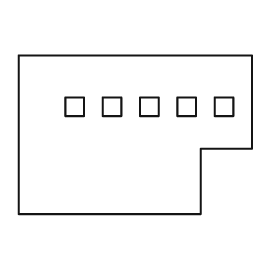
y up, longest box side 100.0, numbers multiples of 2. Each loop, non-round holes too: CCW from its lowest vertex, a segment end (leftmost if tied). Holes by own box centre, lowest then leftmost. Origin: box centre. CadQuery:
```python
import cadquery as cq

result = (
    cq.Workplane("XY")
    .moveTo(-50.0, -34.0)
    .lineTo(28.0, -34.0)
    .lineTo(28.0, -6.0)
    .lineTo(50.0, -6.0)
    .lineTo(50.0, 34.0)
    .lineTo(-50.0, 34.0)
    .close()
    .moveTo(-30.0, 8.0)
    .lineTo(-22.0, 8.0)
    .lineTo(-22.0, 16.0)
    .lineTo(-30.0, 16.0)
    .close()
    .moveTo(-14.0, 8.0)
    .lineTo(-6.0, 8.0)
    .lineTo(-6.0, 16.0)
    .lineTo(-14.0, 16.0)
    .close()
    .moveTo(2.0, 8.0)
    .lineTo(10.0, 8.0)
    .lineTo(10.0, 16.0)
    .lineTo(2.0, 16.0)
    .close()
    .moveTo(18.0, 8.0)
    .lineTo(26.0, 8.0)
    .lineTo(26.0, 16.0)
    .lineTo(18.0, 16.0)
    .close()
    .moveTo(34.0, 8.0)
    .lineTo(42.0, 8.0)
    .lineTo(42.0, 16.0)
    .lineTo(34.0, 16.0)
    .close()
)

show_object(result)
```